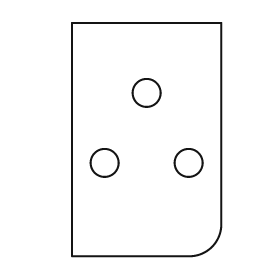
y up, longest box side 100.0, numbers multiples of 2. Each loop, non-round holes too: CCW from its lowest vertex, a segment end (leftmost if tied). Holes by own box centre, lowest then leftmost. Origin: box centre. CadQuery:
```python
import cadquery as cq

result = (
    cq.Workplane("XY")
    .moveTo(-32.0, -50.0)
    .lineTo(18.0, -50.0)
    .threePointArc((28.0, -46.0), (32.0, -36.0))
    .lineTo(32.0, 50.0)
    .lineTo(-32.0, 50.0)
    .close()
    .moveTo(-18.0, -10.0)
    .circle(6.0)
    .moveTo(18.0, -10.0)
    .circle(6.0)
    .moveTo(0.0, 20.0)
    .circle(6.0)
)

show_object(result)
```